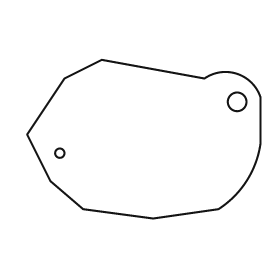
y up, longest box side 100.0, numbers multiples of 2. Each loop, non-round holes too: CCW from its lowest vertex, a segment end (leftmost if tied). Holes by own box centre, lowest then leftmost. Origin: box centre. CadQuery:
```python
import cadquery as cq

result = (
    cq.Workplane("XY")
    .moveTo(4.0, -34.0)
    .lineTo(32.0, -30.0)
    .threePointArc((44.0, -18.0), (50.0, -2.0))
    .lineTo(50.0, 18.0)
    .threePointArc((40.0, 28.0), (26.0, 26.0))
    .lineTo(-18.0, 34.0)
    .lineTo(-34.0, 26.0)
    .lineTo(-50.0, 2.0)
    .lineTo(-40.0, -18.0)
    .lineTo(-26.0, -30.0)
    .close()
    .moveTo(-36.0, -6.0)
    .circle(2.0)
    .moveTo(40.0, 16.0)
    .circle(4.0)
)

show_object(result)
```